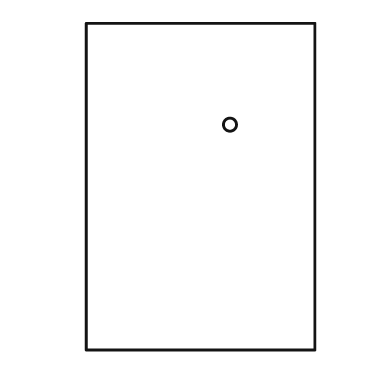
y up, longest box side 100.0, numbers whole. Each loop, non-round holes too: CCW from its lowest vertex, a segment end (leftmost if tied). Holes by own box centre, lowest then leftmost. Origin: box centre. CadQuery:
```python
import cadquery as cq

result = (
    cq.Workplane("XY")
    .moveTo(-35.0, -50.0)
    .lineTo(35.0, -50.0)
    .lineTo(35.0, 50.0)
    .lineTo(-35.0, 50.0)
    .close()
    .moveTo(9.0, 19.0)
    .circle(2.0)
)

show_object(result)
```